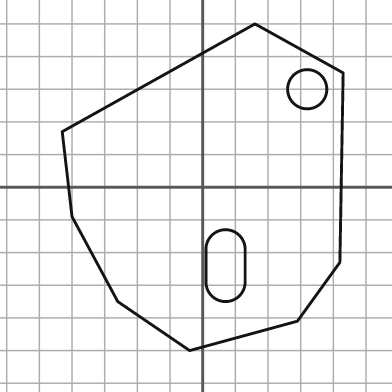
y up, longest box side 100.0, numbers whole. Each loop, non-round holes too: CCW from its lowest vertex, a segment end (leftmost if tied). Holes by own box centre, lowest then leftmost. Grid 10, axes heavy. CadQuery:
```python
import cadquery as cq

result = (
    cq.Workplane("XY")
    .moveTo(-4.0, -50.0)
    .lineTo(29.0, -41.0)
    .lineTo(42.0, -23.0)
    .lineTo(43.0, 35.0)
    .lineTo(16.0, 50.0)
    .lineTo(-43.0, 17.0)
    .lineTo(-40.0, -9.0)
    .lineTo(-26.0, -35.0)
    .close()
    .moveTo(1.0, -29.0)
    .threePointArc((7.0, -35.0), (13.0, -29.0))
    .lineTo(13.0, -19.0)
    .threePointArc((7.0, -13.0), (1.0, -19.0))
    .close()
    .moveTo(32.0, 30.0)
    .circle(6.0)
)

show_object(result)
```